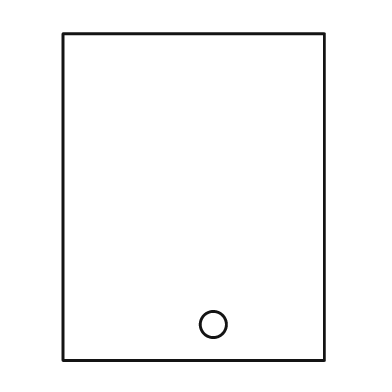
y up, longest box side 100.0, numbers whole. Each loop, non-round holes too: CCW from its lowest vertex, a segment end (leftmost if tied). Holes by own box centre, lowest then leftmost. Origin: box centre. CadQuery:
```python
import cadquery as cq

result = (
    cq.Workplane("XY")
    .moveTo(-40.0, -50.0)
    .lineTo(40.0, -50.0)
    .lineTo(40.0, 50.0)
    .lineTo(-40.0, 50.0)
    .close()
    .moveTo(6.0, -39.0)
    .circle(4.0)
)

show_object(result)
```